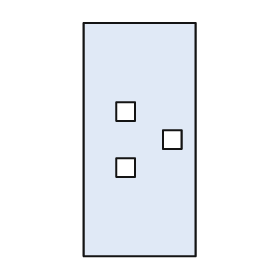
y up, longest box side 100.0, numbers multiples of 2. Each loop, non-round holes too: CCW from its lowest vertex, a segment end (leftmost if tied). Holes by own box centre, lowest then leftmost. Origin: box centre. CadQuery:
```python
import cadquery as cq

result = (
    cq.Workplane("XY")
    .moveTo(-24.0, -50.0)
    .lineTo(24.0, -50.0)
    .lineTo(24.0, 50.0)
    .lineTo(-24.0, 50.0)
    .close()
    .moveTo(-10.0, -16.0)
    .lineTo(-2.0, -16.0)
    .lineTo(-2.0, -8.0)
    .lineTo(-10.0, -8.0)
    .close()
    .moveTo(10.0, -4.0)
    .lineTo(18.0, -4.0)
    .lineTo(18.0, 4.0)
    .lineTo(10.0, 4.0)
    .close()
    .moveTo(-10.0, 8.0)
    .lineTo(-2.0, 8.0)
    .lineTo(-2.0, 16.0)
    .lineTo(-10.0, 16.0)
    .close()
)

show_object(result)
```